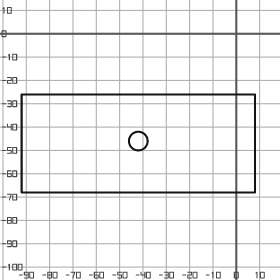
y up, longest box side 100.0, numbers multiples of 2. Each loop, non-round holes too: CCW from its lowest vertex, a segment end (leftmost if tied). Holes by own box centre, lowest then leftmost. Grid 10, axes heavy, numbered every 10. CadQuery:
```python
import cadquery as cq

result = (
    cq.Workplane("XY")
    .moveTo(-92.0, -68.0)
    .lineTo(8.0, -68.0)
    .lineTo(8.0, -26.0)
    .lineTo(-92.0, -26.0)
    .close()
    .moveTo(-42.0, -46.0)
    .circle(4.0)
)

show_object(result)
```